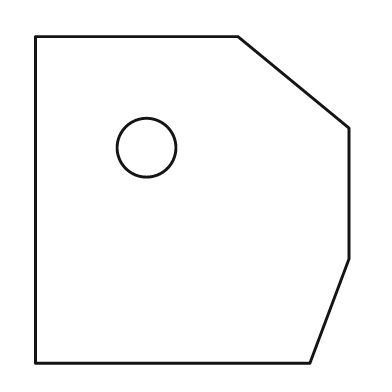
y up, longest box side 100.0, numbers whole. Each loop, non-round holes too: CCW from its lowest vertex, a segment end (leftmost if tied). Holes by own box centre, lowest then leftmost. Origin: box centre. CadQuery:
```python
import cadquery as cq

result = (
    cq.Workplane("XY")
    .moveTo(-48.0, -50.0)
    .lineTo(36.0, -50.0)
    .lineTo(48.0, -18.0)
    .lineTo(48.0, 22.0)
    .lineTo(14.0, 50.0)
    .lineTo(-48.0, 50.0)
    .close()
    .moveTo(-14.0, 16.0)
    .circle(9.0)
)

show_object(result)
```